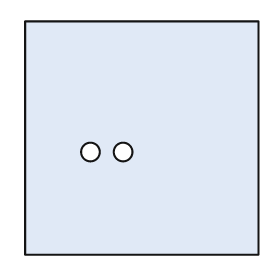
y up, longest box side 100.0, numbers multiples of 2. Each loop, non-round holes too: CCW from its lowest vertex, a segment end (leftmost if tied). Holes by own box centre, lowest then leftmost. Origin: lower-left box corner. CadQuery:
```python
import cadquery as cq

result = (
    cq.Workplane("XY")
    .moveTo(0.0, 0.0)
    .lineTo(100.0, 0.0)
    .lineTo(100.0, 100.0)
    .lineTo(0.0, 100.0)
    .close()
    .moveTo(28.0, 44.0)
    .circle(4.0)
    .moveTo(42.0, 44.0)
    .circle(4.0)
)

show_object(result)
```